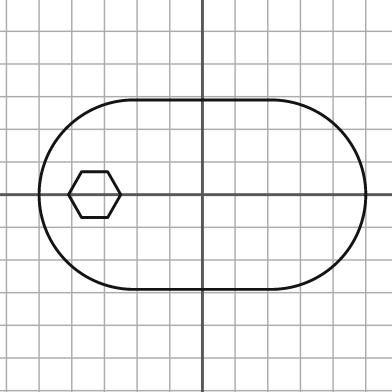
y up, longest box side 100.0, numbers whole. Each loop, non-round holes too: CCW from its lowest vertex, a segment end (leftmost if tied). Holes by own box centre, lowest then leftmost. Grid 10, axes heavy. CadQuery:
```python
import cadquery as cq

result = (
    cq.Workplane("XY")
    .moveTo(-21.0, -29.0)
    .lineTo(21.0, -29.0)
    .threePointArc((50.0, 0.0), (21.0, 29.0))
    .lineTo(-21.0, 29.0)
    .threePointArc((-50.0, 0.0), (-21.0, -29.0))
    .close()
    .moveTo(-37.0, -7.0)
    .lineTo(-29.0, -7.0)
    .lineTo(-25.0, 0.0)
    .lineTo(-29.0, 7.0)
    .lineTo(-37.0, 7.0)
    .lineTo(-41.0, 0.0)
    .close()
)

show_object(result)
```